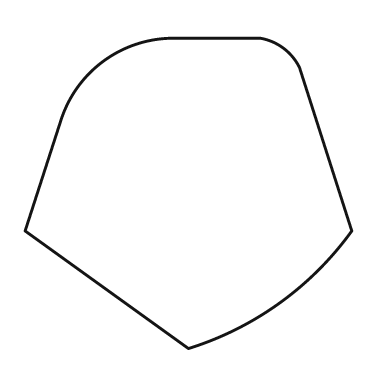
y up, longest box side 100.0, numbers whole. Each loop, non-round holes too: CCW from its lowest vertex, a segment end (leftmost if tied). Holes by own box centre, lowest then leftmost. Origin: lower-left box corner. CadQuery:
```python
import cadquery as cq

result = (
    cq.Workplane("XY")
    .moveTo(50.0, 0.0)
    .threePointArc((78.0, 14.0), (100.0, 36.0))
    .lineTo(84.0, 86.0)
    .threePointArc((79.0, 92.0), (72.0, 95.0))
    .lineTo(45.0, 95.0)
    .threePointArc((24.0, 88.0), (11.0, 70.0))
    .lineTo(0.0, 36.0)
    .close()
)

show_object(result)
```